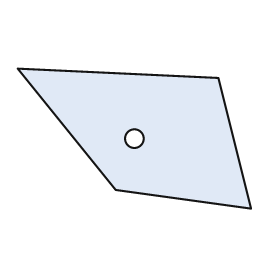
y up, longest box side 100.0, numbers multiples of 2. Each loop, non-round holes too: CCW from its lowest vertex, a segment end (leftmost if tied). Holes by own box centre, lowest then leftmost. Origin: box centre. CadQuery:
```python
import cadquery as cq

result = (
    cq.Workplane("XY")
    .moveTo(50.0, -30.0)
    .lineTo(36.0, 26.0)
    .lineTo(-50.0, 30.0)
    .lineTo(-8.0, -22.0)
    .close()
    .moveTo(0.0, 0.0)
    .circle(4.0)
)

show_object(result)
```